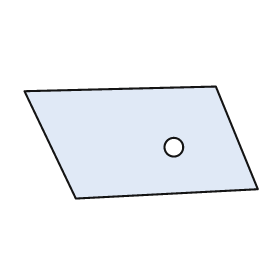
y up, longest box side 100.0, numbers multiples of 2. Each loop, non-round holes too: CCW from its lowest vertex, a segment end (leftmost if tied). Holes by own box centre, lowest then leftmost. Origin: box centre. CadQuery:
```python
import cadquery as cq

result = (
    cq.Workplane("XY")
    .moveTo(-28.0, -24.0)
    .lineTo(50.0, -20.0)
    .lineTo(32.0, 24.0)
    .lineTo(-50.0, 22.0)
    .close()
    .moveTo(14.0, -2.0)
    .circle(4.0)
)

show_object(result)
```